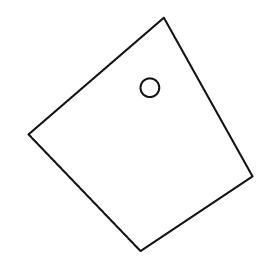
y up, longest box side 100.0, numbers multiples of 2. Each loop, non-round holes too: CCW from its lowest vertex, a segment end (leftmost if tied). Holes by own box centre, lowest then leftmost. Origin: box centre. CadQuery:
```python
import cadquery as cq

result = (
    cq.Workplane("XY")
    .moveTo(0.0, -50.0)
    .lineTo(48.0, -18.0)
    .lineTo(10.0, 50.0)
    .lineTo(-48.0, 0.0)
    .close()
    .moveTo(4.0, 20.0)
    .circle(4.0)
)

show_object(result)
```